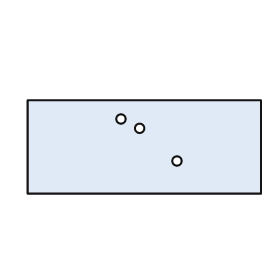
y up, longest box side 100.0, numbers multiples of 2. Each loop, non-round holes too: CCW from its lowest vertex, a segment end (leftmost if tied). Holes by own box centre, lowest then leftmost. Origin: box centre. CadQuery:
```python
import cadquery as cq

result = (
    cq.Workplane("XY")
    .moveTo(-50.0, -20.0)
    .lineTo(50.0, -20.0)
    .lineTo(50.0, 20.0)
    .lineTo(-50.0, 20.0)
    .close()
    .moveTo(14.0, -6.0)
    .circle(2.0)
    .moveTo(-2.0, 8.0)
    .circle(2.0)
    .moveTo(-10.0, 12.0)
    .circle(2.0)
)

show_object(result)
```